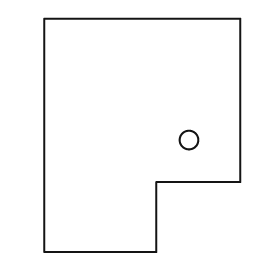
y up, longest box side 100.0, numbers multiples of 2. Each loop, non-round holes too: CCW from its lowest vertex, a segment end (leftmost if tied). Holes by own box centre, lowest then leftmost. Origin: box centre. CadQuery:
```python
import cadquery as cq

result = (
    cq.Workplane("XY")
    .moveTo(-42.0, -50.0)
    .lineTo(6.0, -50.0)
    .lineTo(6.0, -20.0)
    .lineTo(42.0, -20.0)
    .lineTo(42.0, 50.0)
    .lineTo(-42.0, 50.0)
    .close()
    .moveTo(20.0, -2.0)
    .circle(4.0)
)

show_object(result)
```